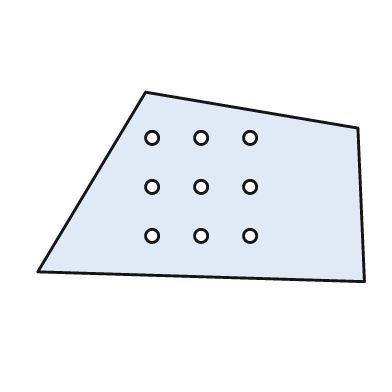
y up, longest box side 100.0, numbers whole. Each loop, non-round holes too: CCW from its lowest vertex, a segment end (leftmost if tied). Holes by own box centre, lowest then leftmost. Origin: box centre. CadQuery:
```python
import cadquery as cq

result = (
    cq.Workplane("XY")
    .moveTo(50.0, -29.0)
    .lineTo(48.0, 18.0)
    .lineTo(-17.0, 29.0)
    .lineTo(-50.0, -26.0)
    .close()
    .moveTo(-15.0, -15.0)
    .circle(2.0)
    .moveTo(0.0, -15.0)
    .circle(2.0)
    .moveTo(15.0, -15.0)
    .circle(2.0)
    .moveTo(-15.0, 0.0)
    .circle(2.0)
    .moveTo(0.0, 0.0)
    .circle(2.0)
    .moveTo(15.0, 0.0)
    .circle(2.0)
    .moveTo(-15.0, 15.0)
    .circle(2.0)
    .moveTo(0.0, 15.0)
    .circle(2.0)
    .moveTo(15.0, 15.0)
    .circle(2.0)
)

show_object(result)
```